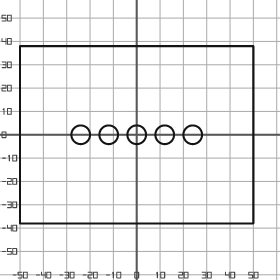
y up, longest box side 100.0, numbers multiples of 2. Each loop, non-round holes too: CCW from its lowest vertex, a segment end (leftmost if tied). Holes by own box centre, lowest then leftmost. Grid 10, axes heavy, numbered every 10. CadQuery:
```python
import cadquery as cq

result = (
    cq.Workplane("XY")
    .moveTo(-50.0, -38.0)
    .lineTo(50.0, -38.0)
    .lineTo(50.0, 38.0)
    .lineTo(-50.0, 38.0)
    .close()
    .moveTo(-24.0, 0.0)
    .circle(4.0)
    .moveTo(-12.0, 0.0)
    .circle(4.0)
    .moveTo(0.0, 0.0)
    .circle(4.0)
    .moveTo(12.0, 0.0)
    .circle(4.0)
    .moveTo(24.0, 0.0)
    .circle(4.0)
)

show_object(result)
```